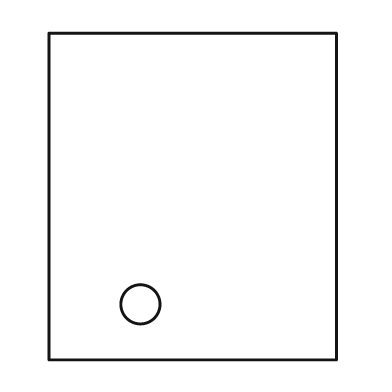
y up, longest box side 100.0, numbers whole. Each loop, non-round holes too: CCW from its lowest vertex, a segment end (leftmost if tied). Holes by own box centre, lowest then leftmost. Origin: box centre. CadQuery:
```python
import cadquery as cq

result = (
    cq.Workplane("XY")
    .moveTo(-44.0, -50.0)
    .lineTo(44.0, -50.0)
    .lineTo(44.0, 50.0)
    .lineTo(-44.0, 50.0)
    .close()
    .moveTo(-16.0, -33.0)
    .circle(6.0)
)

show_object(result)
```